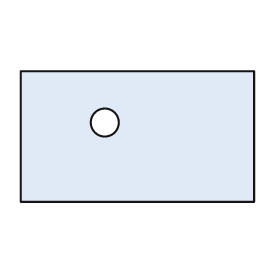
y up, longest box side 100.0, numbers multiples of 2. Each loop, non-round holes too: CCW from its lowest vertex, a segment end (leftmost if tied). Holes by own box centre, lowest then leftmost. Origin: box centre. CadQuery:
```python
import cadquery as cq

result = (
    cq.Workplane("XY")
    .moveTo(-50.0, -28.0)
    .lineTo(50.0, -28.0)
    .lineTo(50.0, 28.0)
    .lineTo(-50.0, 28.0)
    .close()
    .moveTo(-14.0, 6.0)
    .circle(6.0)
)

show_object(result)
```